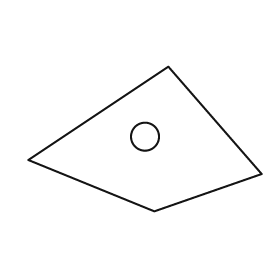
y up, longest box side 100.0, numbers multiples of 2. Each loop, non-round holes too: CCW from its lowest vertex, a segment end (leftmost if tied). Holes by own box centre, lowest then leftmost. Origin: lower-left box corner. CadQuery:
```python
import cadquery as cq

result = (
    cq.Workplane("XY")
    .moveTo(54.0, 0.0)
    .lineTo(100.0, 16.0)
    .lineTo(60.0, 62.0)
    .lineTo(0.0, 22.0)
    .close()
    .moveTo(50.0, 32.0)
    .circle(6.0)
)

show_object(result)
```